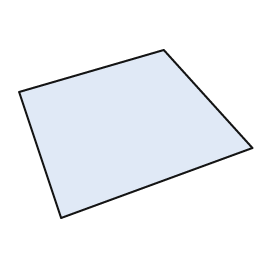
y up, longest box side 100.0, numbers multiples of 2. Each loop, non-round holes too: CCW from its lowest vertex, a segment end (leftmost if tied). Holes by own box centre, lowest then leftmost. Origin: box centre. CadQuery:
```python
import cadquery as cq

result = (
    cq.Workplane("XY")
    .moveTo(-32.0, -36.0)
    .lineTo(50.0, -6.0)
    .lineTo(12.0, 36.0)
    .lineTo(-50.0, 18.0)
    .close()
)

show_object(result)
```